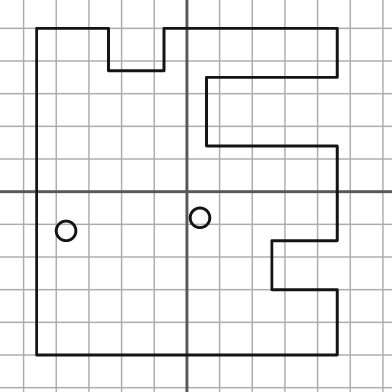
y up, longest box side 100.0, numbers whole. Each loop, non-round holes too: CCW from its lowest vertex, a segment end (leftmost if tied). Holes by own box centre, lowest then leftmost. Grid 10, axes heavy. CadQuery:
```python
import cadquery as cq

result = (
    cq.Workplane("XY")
    .moveTo(-46.0, -50.0)
    .lineTo(46.0, -50.0)
    .lineTo(46.0, -30.0)
    .lineTo(26.0, -30.0)
    .lineTo(26.0, -15.0)
    .lineTo(46.0, -15.0)
    .lineTo(46.0, 14.0)
    .lineTo(6.0, 14.0)
    .lineTo(6.0, 35.0)
    .lineTo(46.0, 35.0)
    .lineTo(46.0, 50.0)
    .lineTo(-7.0, 50.0)
    .lineTo(-7.0, 37.0)
    .lineTo(-24.0, 37.0)
    .lineTo(-24.0, 50.0)
    .lineTo(-46.0, 50.0)
    .close()
    .moveTo(-37.0, -12.0)
    .circle(3.0)
    .moveTo(4.0, -8.0)
    .circle(3.0)
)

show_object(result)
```